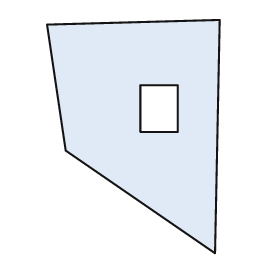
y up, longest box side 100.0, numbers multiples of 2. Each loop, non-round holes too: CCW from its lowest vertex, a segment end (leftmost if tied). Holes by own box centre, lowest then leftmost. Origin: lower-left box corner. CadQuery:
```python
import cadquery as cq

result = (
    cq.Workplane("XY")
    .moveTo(72.0, 0.0)
    .lineTo(74.0, 100.0)
    .lineTo(0.0, 98.0)
    .lineTo(8.0, 44.0)
    .close()
    .moveTo(40.0, 52.0)
    .lineTo(56.0, 52.0)
    .lineTo(56.0, 72.0)
    .lineTo(40.0, 72.0)
    .close()
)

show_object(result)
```